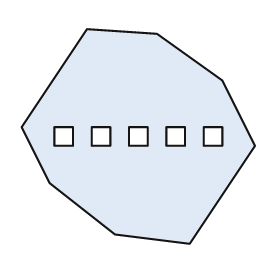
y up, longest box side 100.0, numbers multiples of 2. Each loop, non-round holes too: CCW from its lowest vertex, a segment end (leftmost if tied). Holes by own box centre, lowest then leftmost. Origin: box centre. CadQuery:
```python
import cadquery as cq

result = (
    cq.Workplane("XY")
    .moveTo(22.0, -46.0)
    .lineTo(50.0, -4.0)
    .lineTo(36.0, 24.0)
    .lineTo(8.0, 44.0)
    .lineTo(-22.0, 46.0)
    .lineTo(-50.0, 4.0)
    .lineTo(-38.0, -20.0)
    .lineTo(-10.0, -42.0)
    .close()
    .moveTo(-36.0, -4.0)
    .lineTo(-28.0, -4.0)
    .lineTo(-28.0, 4.0)
    .lineTo(-36.0, 4.0)
    .close()
    .moveTo(-20.0, -4.0)
    .lineTo(-12.0, -4.0)
    .lineTo(-12.0, 4.0)
    .lineTo(-20.0, 4.0)
    .close()
    .moveTo(-4.0, -4.0)
    .lineTo(4.0, -4.0)
    .lineTo(4.0, 4.0)
    .lineTo(-4.0, 4.0)
    .close()
    .moveTo(12.0, -4.0)
    .lineTo(20.0, -4.0)
    .lineTo(20.0, 4.0)
    .lineTo(12.0, 4.0)
    .close()
    .moveTo(28.0, -4.0)
    .lineTo(36.0, -4.0)
    .lineTo(36.0, 4.0)
    .lineTo(28.0, 4.0)
    .close()
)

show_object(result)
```